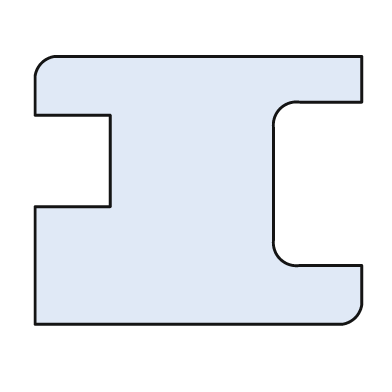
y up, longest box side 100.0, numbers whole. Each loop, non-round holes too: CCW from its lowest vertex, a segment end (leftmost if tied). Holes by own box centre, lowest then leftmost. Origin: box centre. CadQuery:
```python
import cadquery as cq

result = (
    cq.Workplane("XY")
    .moveTo(-50.0, -41.0)
    .lineTo(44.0, -41.0)
    .threePointArc((48.0, -39.0), (50.0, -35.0))
    .lineTo(50.0, -23.0)
    .lineTo(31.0, -23.0)
    .threePointArc((25.0, -21.0), (23.0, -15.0))
    .lineTo(23.0, 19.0)
    .threePointArc((25.0, 25.0), (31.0, 27.0))
    .lineTo(50.0, 27.0)
    .lineTo(50.0, 41.0)
    .lineTo(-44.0, 41.0)
    .threePointArc((-48.0, 39.0), (-50.0, 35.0))
    .lineTo(-50.0, 23.0)
    .lineTo(-27.0, 23.0)
    .lineTo(-27.0, -5.0)
    .lineTo(-50.0, -5.0)
    .close()
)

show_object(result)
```